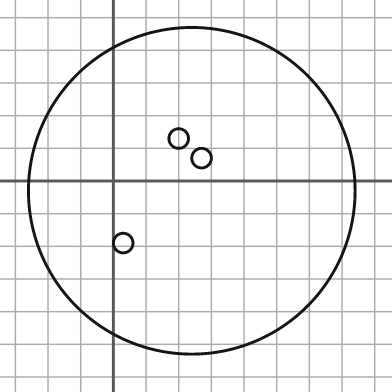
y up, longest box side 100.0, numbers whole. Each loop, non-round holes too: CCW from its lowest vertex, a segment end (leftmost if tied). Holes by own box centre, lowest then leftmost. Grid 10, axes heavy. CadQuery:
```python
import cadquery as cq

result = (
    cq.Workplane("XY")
    .moveTo(24.0, -3.0)
    .circle(50.0)
    .moveTo(3.0, -19.0)
    .circle(3.0)
    .moveTo(27.0, 7.0)
    .circle(3.0)
    .moveTo(20.0, 13.0)
    .circle(3.0)
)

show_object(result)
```